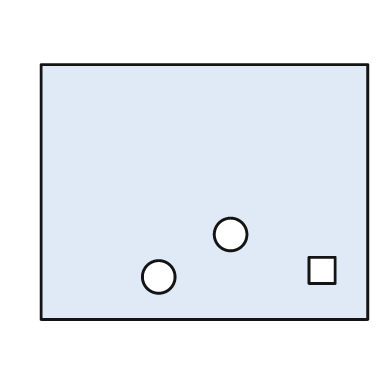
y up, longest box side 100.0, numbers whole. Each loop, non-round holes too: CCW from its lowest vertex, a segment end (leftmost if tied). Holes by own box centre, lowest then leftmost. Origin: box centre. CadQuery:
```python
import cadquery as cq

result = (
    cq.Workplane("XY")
    .moveTo(-50.0, -39.0)
    .lineTo(50.0, -39.0)
    .lineTo(50.0, 39.0)
    .lineTo(-50.0, 39.0)
    .close()
    .moveTo(-14.0, -26.0)
    .circle(5.0)
    .moveTo(32.0, -28.0)
    .lineTo(40.0, -28.0)
    .lineTo(40.0, -20.0)
    .lineTo(32.0, -20.0)
    .close()
    .moveTo(8.0, -13.0)
    .circle(5.0)
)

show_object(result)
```